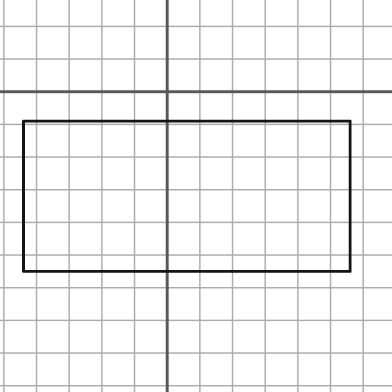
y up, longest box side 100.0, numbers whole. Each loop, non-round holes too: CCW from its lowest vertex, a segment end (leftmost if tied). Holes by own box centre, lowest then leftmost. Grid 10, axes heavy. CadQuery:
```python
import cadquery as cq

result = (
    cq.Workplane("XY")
    .moveTo(-44.0, -55.0)
    .lineTo(56.0, -55.0)
    .lineTo(56.0, -9.0)
    .lineTo(-44.0, -9.0)
    .close()
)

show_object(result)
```